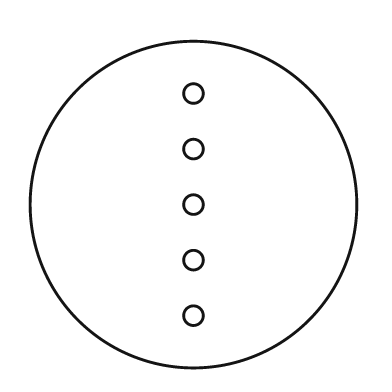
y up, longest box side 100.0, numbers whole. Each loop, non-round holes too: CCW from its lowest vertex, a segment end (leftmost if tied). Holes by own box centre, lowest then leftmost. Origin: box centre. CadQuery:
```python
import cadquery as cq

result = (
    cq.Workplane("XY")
    .moveTo(0.0, 0.0)
    .circle(50.0)
    .moveTo(0.0, -34.0)
    .circle(3.0)
    .moveTo(0.0, -17.0)
    .circle(3.0)
    .moveTo(0.0, 0.0)
    .circle(3.0)
    .moveTo(0.0, 17.0)
    .circle(3.0)
    .moveTo(0.0, 34.0)
    .circle(3.0)
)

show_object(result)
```